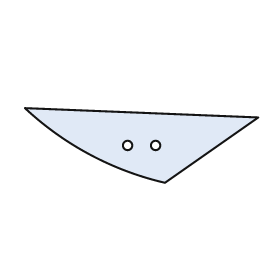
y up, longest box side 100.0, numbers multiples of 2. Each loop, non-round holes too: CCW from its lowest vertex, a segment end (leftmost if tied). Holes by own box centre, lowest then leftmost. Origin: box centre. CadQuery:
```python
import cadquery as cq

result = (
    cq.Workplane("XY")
    .moveTo(10.0, -16.0)
    .lineTo(50.0, 12.0)
    .lineTo(-50.0, 16.0)
    .threePointArc((-22.0, -4.0), (10.0, -16.0))
    .close()
    .moveTo(-6.0, 0.0)
    .circle(2.0)
    .moveTo(6.0, 0.0)
    .circle(2.0)
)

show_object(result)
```